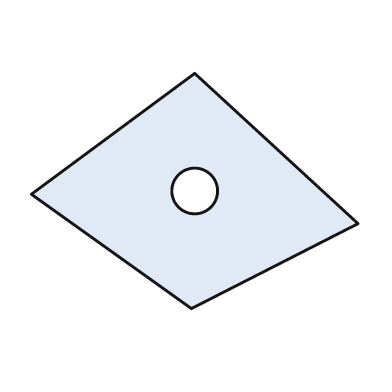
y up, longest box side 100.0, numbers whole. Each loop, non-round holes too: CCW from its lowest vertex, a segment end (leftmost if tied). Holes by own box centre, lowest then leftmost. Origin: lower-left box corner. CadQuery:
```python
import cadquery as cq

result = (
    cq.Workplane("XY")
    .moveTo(49.0, 0.0)
    .lineTo(100.0, 26.0)
    .lineTo(50.0, 72.0)
    .lineTo(0.0, 35.0)
    .close()
    .moveTo(50.0, 36.0)
    .circle(7.0)
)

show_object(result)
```